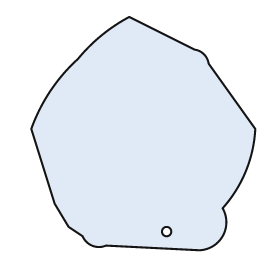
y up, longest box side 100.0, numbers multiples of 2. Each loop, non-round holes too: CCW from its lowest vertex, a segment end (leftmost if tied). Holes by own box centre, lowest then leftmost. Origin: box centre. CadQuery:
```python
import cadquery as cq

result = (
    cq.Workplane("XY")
    .moveTo(24.0, -50.0)
    .threePointArc((34.0, -44.0), (34.0, -32.0))
    .threePointArc((44.0, -16.0), (48.0, 2.0))
    .lineTo(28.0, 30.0)
    .threePointArc((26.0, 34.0), (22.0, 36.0))
    .lineTo(-6.0, 50.0)
    .threePointArc((-18.0, 42.0), (-28.0, 32.0))
    .threePointArc((-40.0, 18.0), (-48.0, 2.0))
    .lineTo(-38.0, -30.0)
    .lineTo(-32.0, -40.0)
    .lineTo(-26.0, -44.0)
    .threePointArc((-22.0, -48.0), (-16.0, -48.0))
    .close()
    .moveTo(10.0, -42.0)
    .circle(2.0)
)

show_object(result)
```